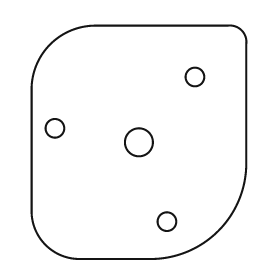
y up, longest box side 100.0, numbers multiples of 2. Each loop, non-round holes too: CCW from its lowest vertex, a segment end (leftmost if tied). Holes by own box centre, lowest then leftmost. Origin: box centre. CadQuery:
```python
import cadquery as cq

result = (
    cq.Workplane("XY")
    .moveTo(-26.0, -50.0)
    .lineTo(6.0, -50.0)
    .threePointArc((34.0, -38.0), (46.0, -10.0))
    .lineTo(46.0, 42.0)
    .threePointArc((44.0, 48.0), (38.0, 50.0))
    .lineTo(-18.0, 50.0)
    .threePointArc((-38.0, 42.0), (-46.0, 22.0))
    .lineTo(-46.0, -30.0)
    .threePointArc((-40.0, -44.0), (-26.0, -50.0))
    .close()
    .moveTo(12.0, -34.0)
    .circle(4.0)
    .moveTo(0.0, 0.0)
    .circle(6.0)
    .moveTo(-36.0, 6.0)
    .circle(4.0)
    .moveTo(24.0, 28.0)
    .circle(4.0)
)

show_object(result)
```